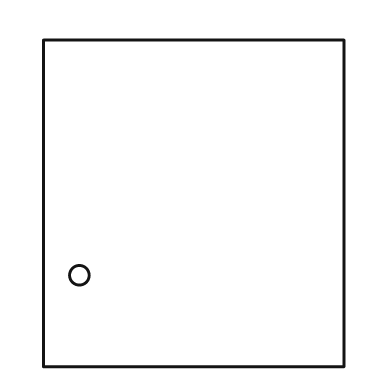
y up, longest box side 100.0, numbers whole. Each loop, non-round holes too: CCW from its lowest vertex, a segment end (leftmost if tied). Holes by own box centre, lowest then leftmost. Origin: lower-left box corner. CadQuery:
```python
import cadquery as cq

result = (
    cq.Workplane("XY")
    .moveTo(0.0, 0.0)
    .lineTo(92.0, 0.0)
    .lineTo(92.0, 100.0)
    .lineTo(0.0, 100.0)
    .close()
    .moveTo(11.0, 28.0)
    .circle(3.0)
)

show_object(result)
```